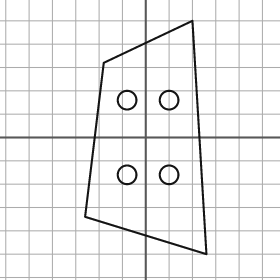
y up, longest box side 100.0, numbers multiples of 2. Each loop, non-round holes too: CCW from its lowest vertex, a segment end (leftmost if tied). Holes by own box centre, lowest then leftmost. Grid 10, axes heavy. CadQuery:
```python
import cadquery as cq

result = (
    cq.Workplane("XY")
    .moveTo(26.0, -50.0)
    .lineTo(20.0, 50.0)
    .lineTo(-18.0, 32.0)
    .lineTo(-26.0, -34.0)
    .close()
    .moveTo(-8.0, -16.0)
    .circle(4.0)
    .moveTo(10.0, -16.0)
    .circle(4.0)
    .moveTo(-8.0, 16.0)
    .circle(4.0)
    .moveTo(10.0, 16.0)
    .circle(4.0)
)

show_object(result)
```